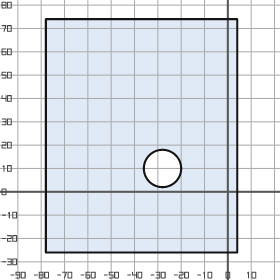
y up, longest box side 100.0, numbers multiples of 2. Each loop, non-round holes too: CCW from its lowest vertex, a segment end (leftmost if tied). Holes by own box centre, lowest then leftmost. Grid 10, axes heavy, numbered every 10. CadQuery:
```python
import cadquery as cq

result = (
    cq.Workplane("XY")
    .moveTo(-78.0, -26.0)
    .lineTo(4.0, -26.0)
    .lineTo(4.0, 74.0)
    .lineTo(-78.0, 74.0)
    .close()
    .moveTo(-28.0, 10.0)
    .circle(8.0)
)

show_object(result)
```